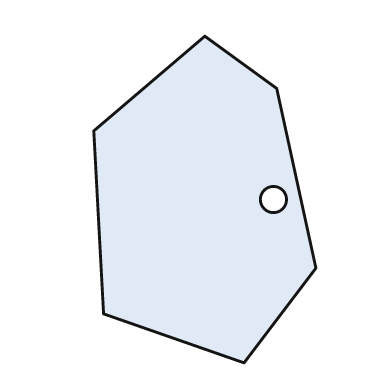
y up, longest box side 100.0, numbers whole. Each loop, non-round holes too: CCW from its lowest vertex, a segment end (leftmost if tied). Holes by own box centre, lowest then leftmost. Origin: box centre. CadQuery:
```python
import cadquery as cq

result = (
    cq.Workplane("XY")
    .moveTo(12.0, -50.0)
    .lineTo(34.0, -21.0)
    .lineTo(22.0, 34.0)
    .lineTo(0.0, 50.0)
    .lineTo(-34.0, 21.0)
    .lineTo(-31.0, -35.0)
    .close()
    .moveTo(21.0, 0.0)
    .circle(4.0)
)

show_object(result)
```